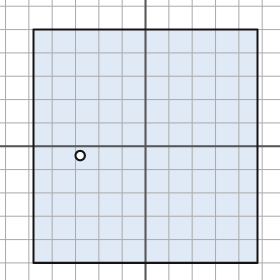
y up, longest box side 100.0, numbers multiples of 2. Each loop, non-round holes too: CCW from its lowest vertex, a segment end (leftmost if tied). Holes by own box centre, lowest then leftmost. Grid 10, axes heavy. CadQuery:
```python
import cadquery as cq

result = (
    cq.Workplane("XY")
    .moveTo(-48.0, -50.0)
    .lineTo(48.0, -50.0)
    .lineTo(48.0, 50.0)
    .lineTo(-48.0, 50.0)
    .close()
    .moveTo(-28.0, -4.0)
    .circle(2.0)
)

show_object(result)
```